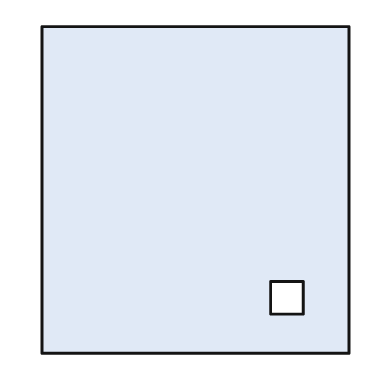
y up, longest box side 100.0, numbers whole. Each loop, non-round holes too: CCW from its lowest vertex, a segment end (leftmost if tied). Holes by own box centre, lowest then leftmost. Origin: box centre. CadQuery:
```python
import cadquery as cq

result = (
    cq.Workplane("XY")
    .moveTo(-47.0, -50.0)
    .lineTo(47.0, -50.0)
    .lineTo(47.0, 50.0)
    .lineTo(-47.0, 50.0)
    .close()
    .moveTo(23.0, -38.0)
    .lineTo(33.0, -38.0)
    .lineTo(33.0, -28.0)
    .lineTo(23.0, -28.0)
    .close()
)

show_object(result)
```